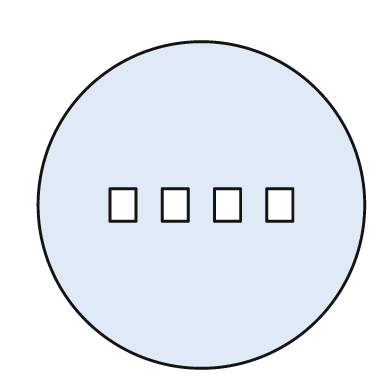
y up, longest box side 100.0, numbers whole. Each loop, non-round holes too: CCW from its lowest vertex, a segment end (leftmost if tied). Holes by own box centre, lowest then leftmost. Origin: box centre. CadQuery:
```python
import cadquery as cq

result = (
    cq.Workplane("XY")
    .moveTo(0.0, 0.0)
    .circle(50.0)
    .moveTo(-28.0, -5.0)
    .lineTo(-20.0, -5.0)
    .lineTo(-20.0, 5.0)
    .lineTo(-28.0, 5.0)
    .close()
    .moveTo(-12.0, -5.0)
    .lineTo(-4.0, -5.0)
    .lineTo(-4.0, 5.0)
    .lineTo(-12.0, 5.0)
    .close()
    .moveTo(4.0, -5.0)
    .lineTo(12.0, -5.0)
    .lineTo(12.0, 5.0)
    .lineTo(4.0, 5.0)
    .close()
    .moveTo(20.0, -5.0)
    .lineTo(28.0, -5.0)
    .lineTo(28.0, 5.0)
    .lineTo(20.0, 5.0)
    .close()
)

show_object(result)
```